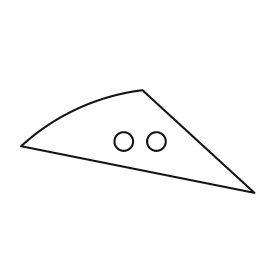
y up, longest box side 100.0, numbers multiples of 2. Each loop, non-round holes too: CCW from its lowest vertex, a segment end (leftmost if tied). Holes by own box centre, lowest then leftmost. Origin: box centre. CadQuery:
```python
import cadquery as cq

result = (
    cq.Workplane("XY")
    .moveTo(50.0, -22.0)
    .lineTo(2.0, 22.0)
    .threePointArc((-26.0, 14.0), (-50.0, -2.0))
    .close()
    .moveTo(-6.0, 0.0)
    .circle(4.0)
    .moveTo(8.0, 0.0)
    .circle(4.0)
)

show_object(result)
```